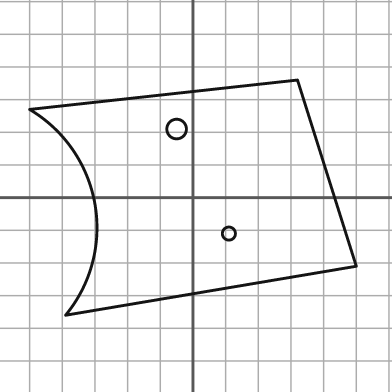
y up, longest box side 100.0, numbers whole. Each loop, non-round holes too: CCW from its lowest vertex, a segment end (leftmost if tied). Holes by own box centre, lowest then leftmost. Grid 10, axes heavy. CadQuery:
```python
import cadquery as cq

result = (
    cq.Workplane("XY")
    .moveTo(-39.0, -36.0)
    .lineTo(50.0, -21.0)
    .lineTo(32.0, 36.0)
    .lineTo(-50.0, 27.0)
    .threePointArc((-30.0, -2.0), (-39.0, -36.0))
    .close()
    .moveTo(11.0, -11.0)
    .circle(2.0)
    .moveTo(-5.0, 21.0)
    .circle(3.0)
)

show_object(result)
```